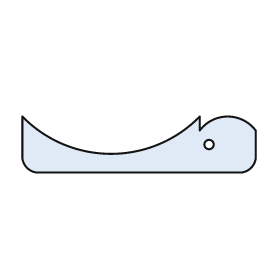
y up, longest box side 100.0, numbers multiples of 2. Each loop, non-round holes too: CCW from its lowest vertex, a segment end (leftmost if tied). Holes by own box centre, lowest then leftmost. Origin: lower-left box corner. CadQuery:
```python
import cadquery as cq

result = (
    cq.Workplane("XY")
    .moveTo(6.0, 0.0)
    .lineTo(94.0, 0.0)
    .threePointArc((98.0, 2.0), (100.0, 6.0))
    .lineTo(100.0, 18.0)
    .threePointArc((88.0, 24.0), (76.0, 18.0))
    .lineTo(76.0, 24.0)
    .threePointArc((38.0, 8.0), (0.0, 24.0))
    .lineTo(0.0, 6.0)
    .threePointArc((2.0, 2.0), (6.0, 0.0))
    .close()
    .moveTo(80.0, 12.0)
    .circle(2.0)
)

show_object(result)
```